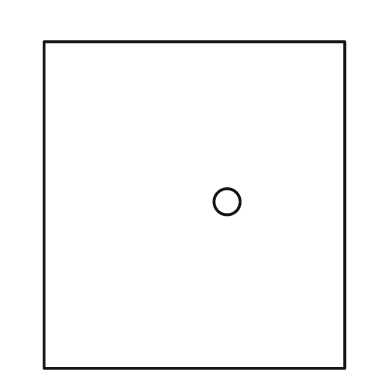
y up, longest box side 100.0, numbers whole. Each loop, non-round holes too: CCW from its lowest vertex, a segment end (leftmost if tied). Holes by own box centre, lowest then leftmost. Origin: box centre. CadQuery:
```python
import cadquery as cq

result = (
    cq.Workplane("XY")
    .moveTo(-46.0, -50.0)
    .lineTo(46.0, -50.0)
    .lineTo(46.0, 50.0)
    .lineTo(-46.0, 50.0)
    .close()
    .moveTo(10.0, 1.0)
    .circle(4.0)
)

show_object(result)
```